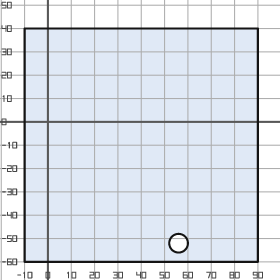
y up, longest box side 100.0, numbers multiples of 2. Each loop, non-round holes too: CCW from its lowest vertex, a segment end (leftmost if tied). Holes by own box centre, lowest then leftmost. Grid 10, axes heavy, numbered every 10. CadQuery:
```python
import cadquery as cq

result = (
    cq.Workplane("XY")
    .moveTo(-10.0, -60.0)
    .lineTo(90.0, -60.0)
    .lineTo(90.0, 40.0)
    .lineTo(-10.0, 40.0)
    .close()
    .moveTo(56.0, -52.0)
    .circle(4.0)
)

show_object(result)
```